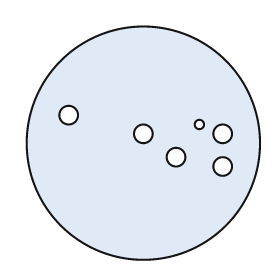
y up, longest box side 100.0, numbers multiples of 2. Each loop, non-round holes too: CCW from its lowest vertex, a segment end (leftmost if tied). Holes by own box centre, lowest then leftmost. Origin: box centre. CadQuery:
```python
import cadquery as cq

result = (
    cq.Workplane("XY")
    .moveTo(0.0, 0.0)
    .circle(50.0)
    .moveTo(34.0, -10.0)
    .circle(4.0)
    .moveTo(14.0, -6.0)
    .circle(4.0)
    .moveTo(0.0, 4.0)
    .circle(4.0)
    .moveTo(34.0, 4.0)
    .circle(4.0)
    .moveTo(24.0, 8.0)
    .circle(2.0)
    .moveTo(-32.0, 12.0)
    .circle(4.0)
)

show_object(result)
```